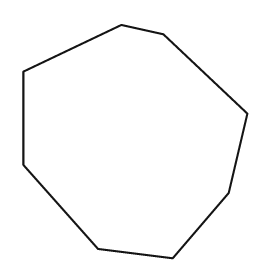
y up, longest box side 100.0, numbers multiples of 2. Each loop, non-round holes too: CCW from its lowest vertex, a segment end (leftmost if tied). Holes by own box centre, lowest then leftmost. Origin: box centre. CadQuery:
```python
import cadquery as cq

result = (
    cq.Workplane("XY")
    .moveTo(16.0, -50.0)
    .lineTo(40.0, -22.0)
    .lineTo(48.0, 12.0)
    .lineTo(12.0, 46.0)
    .lineTo(-6.0, 50.0)
    .lineTo(-48.0, 30.0)
    .lineTo(-48.0, -10.0)
    .lineTo(-16.0, -46.0)
    .close()
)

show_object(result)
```